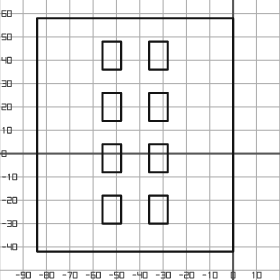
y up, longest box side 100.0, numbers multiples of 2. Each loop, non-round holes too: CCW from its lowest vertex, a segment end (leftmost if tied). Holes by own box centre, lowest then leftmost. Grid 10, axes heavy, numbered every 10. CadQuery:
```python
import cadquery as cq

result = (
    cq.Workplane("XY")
    .moveTo(-84.0, -42.0)
    .lineTo(0.0, -42.0)
    .lineTo(0.0, 58.0)
    .lineTo(-84.0, 58.0)
    .close()
    .moveTo(-56.0, -30.0)
    .lineTo(-48.0, -30.0)
    .lineTo(-48.0, -18.0)
    .lineTo(-56.0, -18.0)
    .close()
    .moveTo(-36.0, -30.0)
    .lineTo(-28.0, -30.0)
    .lineTo(-28.0, -18.0)
    .lineTo(-36.0, -18.0)
    .close()
    .moveTo(-56.0, -8.0)
    .lineTo(-48.0, -8.0)
    .lineTo(-48.0, 4.0)
    .lineTo(-56.0, 4.0)
    .close()
    .moveTo(-36.0, -8.0)
    .lineTo(-28.0, -8.0)
    .lineTo(-28.0, 4.0)
    .lineTo(-36.0, 4.0)
    .close()
    .moveTo(-56.0, 14.0)
    .lineTo(-48.0, 14.0)
    .lineTo(-48.0, 26.0)
    .lineTo(-56.0, 26.0)
    .close()
    .moveTo(-36.0, 14.0)
    .lineTo(-28.0, 14.0)
    .lineTo(-28.0, 26.0)
    .lineTo(-36.0, 26.0)
    .close()
    .moveTo(-56.0, 36.0)
    .lineTo(-48.0, 36.0)
    .lineTo(-48.0, 48.0)
    .lineTo(-56.0, 48.0)
    .close()
    .moveTo(-36.0, 36.0)
    .lineTo(-28.0, 36.0)
    .lineTo(-28.0, 48.0)
    .lineTo(-36.0, 48.0)
    .close()
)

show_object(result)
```